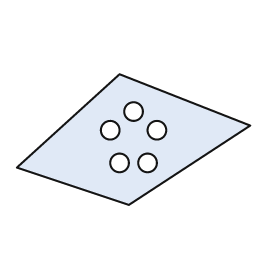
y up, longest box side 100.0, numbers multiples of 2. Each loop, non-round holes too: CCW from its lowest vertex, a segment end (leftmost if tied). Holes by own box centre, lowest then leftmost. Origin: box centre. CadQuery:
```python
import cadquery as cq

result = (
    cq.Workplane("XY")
    .moveTo(-2.0, -28.0)
    .lineTo(50.0, 6.0)
    .lineTo(-6.0, 28.0)
    .lineTo(-50.0, -12.0)
    .close()
    .moveTo(-6.0, -10.0)
    .circle(4.0)
    .moveTo(6.0, -10.0)
    .circle(4.0)
    .moveTo(-10.0, 4.0)
    .circle(4.0)
    .moveTo(10.0, 4.0)
    .circle(4.0)
    .moveTo(0.0, 12.0)
    .circle(4.0)
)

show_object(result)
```